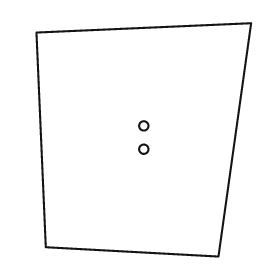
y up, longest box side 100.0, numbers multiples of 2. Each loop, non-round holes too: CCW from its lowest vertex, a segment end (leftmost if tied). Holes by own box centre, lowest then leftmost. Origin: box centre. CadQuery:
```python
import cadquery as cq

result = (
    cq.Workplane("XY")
    .moveTo(32.0, -50.0)
    .lineTo(46.0, 50.0)
    .lineTo(-46.0, 46.0)
    .lineTo(-42.0, -46.0)
    .close()
    .moveTo(0.0, -4.0)
    .circle(2.0)
    .moveTo(0.0, 6.0)
    .circle(2.0)
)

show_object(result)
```